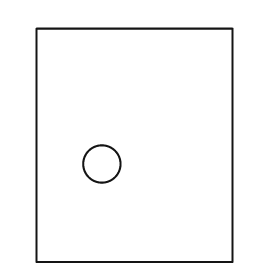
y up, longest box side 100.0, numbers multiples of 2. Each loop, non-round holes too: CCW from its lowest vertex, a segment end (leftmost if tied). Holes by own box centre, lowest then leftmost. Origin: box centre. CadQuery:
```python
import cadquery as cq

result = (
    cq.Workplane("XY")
    .moveTo(-42.0, -50.0)
    .lineTo(42.0, -50.0)
    .lineTo(42.0, 50.0)
    .lineTo(-42.0, 50.0)
    .close()
    .moveTo(-14.0, -8.0)
    .circle(8.0)
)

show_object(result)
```